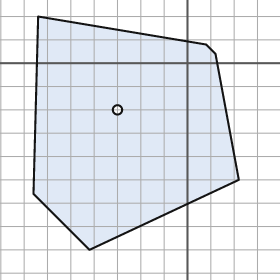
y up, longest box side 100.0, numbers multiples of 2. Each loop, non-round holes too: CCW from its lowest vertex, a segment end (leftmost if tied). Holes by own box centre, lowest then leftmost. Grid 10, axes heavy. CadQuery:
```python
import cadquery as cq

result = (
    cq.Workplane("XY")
    .moveTo(-42.0, -80.0)
    .lineTo(22.0, -50.0)
    .lineTo(12.0, 4.0)
    .lineTo(8.0, 8.0)
    .lineTo(-64.0, 20.0)
    .lineTo(-66.0, -56.0)
    .close()
    .moveTo(-30.0, -20.0)
    .circle(2.0)
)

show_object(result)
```